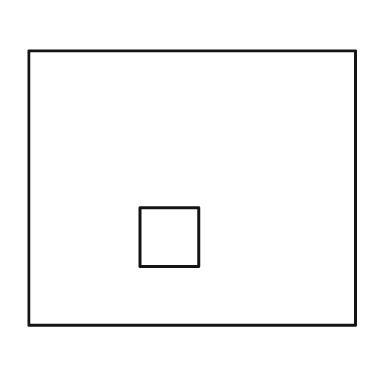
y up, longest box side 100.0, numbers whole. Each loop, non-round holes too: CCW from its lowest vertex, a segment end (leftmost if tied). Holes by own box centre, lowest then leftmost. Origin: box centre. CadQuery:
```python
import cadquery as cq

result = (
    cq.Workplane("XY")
    .moveTo(-50.0, -42.0)
    .lineTo(50.0, -42.0)
    .lineTo(50.0, 42.0)
    .lineTo(-50.0, 42.0)
    .close()
    .moveTo(-16.0, -24.0)
    .lineTo(2.0, -24.0)
    .lineTo(2.0, -6.0)
    .lineTo(-16.0, -6.0)
    .close()
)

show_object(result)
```